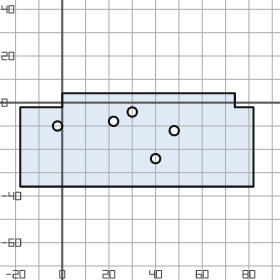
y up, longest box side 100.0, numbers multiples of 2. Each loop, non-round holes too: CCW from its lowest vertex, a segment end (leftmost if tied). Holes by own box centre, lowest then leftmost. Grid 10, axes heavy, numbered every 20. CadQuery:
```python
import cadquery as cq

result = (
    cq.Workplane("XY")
    .moveTo(-18.0, -36.0)
    .lineTo(82.0, -36.0)
    .lineTo(82.0, -2.0)
    .lineTo(74.0, -2.0)
    .lineTo(74.0, 4.0)
    .lineTo(0.0, 4.0)
    .lineTo(0.0, -2.0)
    .lineTo(-18.0, -2.0)
    .close()
    .moveTo(40.0, -24.0)
    .circle(2.0)
    .moveTo(48.0, -12.0)
    .circle(2.0)
    .moveTo(-2.0, -10.0)
    .circle(2.0)
    .moveTo(22.0, -8.0)
    .circle(2.0)
    .moveTo(30.0, -4.0)
    .circle(2.0)
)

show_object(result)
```